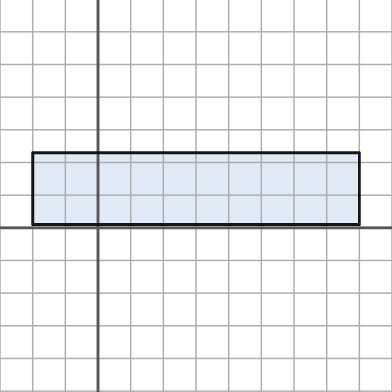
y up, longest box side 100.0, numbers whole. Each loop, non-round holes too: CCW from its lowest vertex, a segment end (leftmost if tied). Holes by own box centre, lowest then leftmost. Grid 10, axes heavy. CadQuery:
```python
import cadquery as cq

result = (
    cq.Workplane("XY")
    .moveTo(-20.0, 1.0)
    .lineTo(80.0, 1.0)
    .lineTo(80.0, 23.0)
    .lineTo(-20.0, 23.0)
    .close()
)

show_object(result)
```